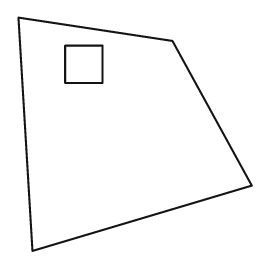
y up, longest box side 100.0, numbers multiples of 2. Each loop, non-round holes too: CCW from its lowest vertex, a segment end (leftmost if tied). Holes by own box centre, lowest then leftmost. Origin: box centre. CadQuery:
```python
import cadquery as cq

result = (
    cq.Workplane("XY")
    .moveTo(-44.0, -50.0)
    .lineTo(50.0, -22.0)
    .lineTo(16.0, 40.0)
    .lineTo(-50.0, 50.0)
    .close()
    .moveTo(-30.0, 22.0)
    .lineTo(-14.0, 22.0)
    .lineTo(-14.0, 38.0)
    .lineTo(-30.0, 38.0)
    .close()
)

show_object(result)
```